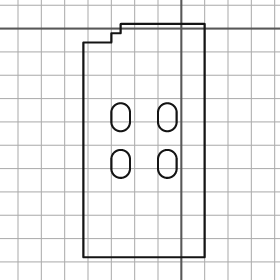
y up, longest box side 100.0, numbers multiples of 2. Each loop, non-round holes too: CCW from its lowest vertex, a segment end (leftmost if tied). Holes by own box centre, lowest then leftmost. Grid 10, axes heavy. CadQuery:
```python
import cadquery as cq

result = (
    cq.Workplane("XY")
    .moveTo(-42.0, -98.0)
    .lineTo(10.0, -98.0)
    .lineTo(10.0, 2.0)
    .lineTo(-26.0, 2.0)
    .lineTo(-26.0, -2.0)
    .lineTo(-30.0, -2.0)
    .lineTo(-30.0, -6.0)
    .lineTo(-42.0, -6.0)
    .close()
    .moveTo(-30.0, -60.0)
    .threePointArc((-26.0, -64.0), (-22.0, -60.0))
    .lineTo(-22.0, -56.0)
    .threePointArc((-26.0, -52.0), (-30.0, -56.0))
    .close()
    .moveTo(-10.0, -60.0)
    .threePointArc((-6.0, -64.0), (-2.0, -60.0))
    .lineTo(-2.0, -56.0)
    .threePointArc((-6.0, -52.0), (-10.0, -56.0))
    .close()
    .moveTo(-30.0, -40.0)
    .threePointArc((-26.0, -44.0), (-22.0, -40.0))
    .lineTo(-22.0, -36.0)
    .threePointArc((-26.0, -32.0), (-30.0, -36.0))
    .close()
    .moveTo(-10.0, -40.0)
    .threePointArc((-6.0, -44.0), (-2.0, -40.0))
    .lineTo(-2.0, -36.0)
    .threePointArc((-6.0, -32.0), (-10.0, -36.0))
    .close()
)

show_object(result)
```